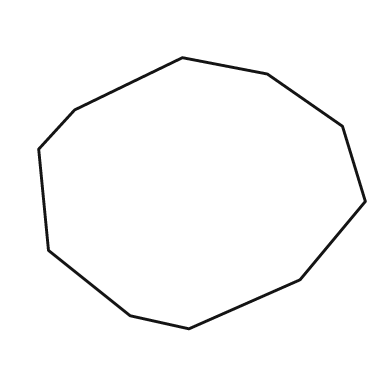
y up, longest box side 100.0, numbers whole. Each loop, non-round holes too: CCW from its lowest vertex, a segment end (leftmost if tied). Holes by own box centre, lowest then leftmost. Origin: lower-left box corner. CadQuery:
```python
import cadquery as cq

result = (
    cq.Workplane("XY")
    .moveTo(46.0, 0.0)
    .lineTo(80.0, 15.0)
    .lineTo(100.0, 39.0)
    .lineTo(93.0, 62.0)
    .lineTo(70.0, 78.0)
    .lineTo(44.0, 83.0)
    .lineTo(11.0, 67.0)
    .lineTo(0.0, 55.0)
    .lineTo(3.0, 24.0)
    .lineTo(28.0, 4.0)
    .close()
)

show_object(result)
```